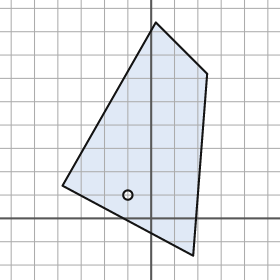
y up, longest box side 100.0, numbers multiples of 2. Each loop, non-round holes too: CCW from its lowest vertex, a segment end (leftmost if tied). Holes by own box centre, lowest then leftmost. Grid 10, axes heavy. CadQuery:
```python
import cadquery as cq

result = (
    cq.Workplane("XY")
    .moveTo(18.0, -16.0)
    .lineTo(24.0, 62.0)
    .lineTo(2.0, 84.0)
    .lineTo(-38.0, 14.0)
    .close()
    .moveTo(-10.0, 10.0)
    .circle(2.0)
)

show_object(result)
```